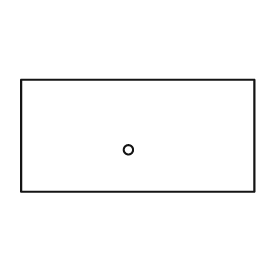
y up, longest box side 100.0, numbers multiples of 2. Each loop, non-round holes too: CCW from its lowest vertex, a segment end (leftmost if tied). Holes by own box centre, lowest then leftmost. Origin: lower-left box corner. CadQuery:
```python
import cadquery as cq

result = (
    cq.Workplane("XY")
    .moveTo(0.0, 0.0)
    .lineTo(100.0, 0.0)
    .lineTo(100.0, 48.0)
    .lineTo(0.0, 48.0)
    .close()
    .moveTo(46.0, 18.0)
    .circle(2.0)
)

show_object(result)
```